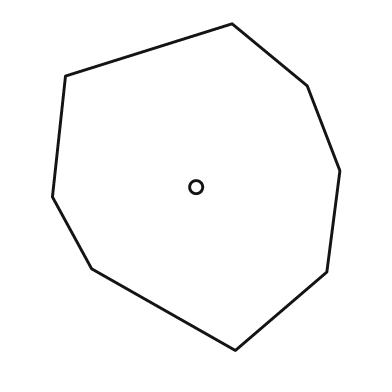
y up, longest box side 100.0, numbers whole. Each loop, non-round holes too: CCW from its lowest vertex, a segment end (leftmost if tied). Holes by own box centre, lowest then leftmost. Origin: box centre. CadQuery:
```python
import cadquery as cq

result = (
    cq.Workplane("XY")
    .moveTo(12.0, -50.0)
    .lineTo(40.0, -26.0)
    .lineTo(44.0, 5.0)
    .lineTo(34.0, 31.0)
    .lineTo(11.0, 50.0)
    .lineTo(-40.0, 34.0)
    .lineTo(-44.0, -3.0)
    .lineTo(-32.0, -25.0)
    .close()
    .moveTo(0.0, 0.0)
    .circle(2.0)
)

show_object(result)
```